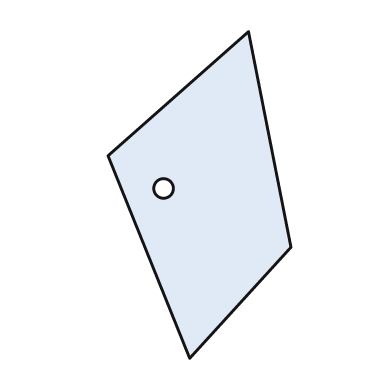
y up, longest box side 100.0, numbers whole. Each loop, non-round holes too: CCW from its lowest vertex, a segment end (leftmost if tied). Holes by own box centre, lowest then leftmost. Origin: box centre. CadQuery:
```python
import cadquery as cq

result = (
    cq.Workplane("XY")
    .moveTo(-3.0, -50.0)
    .lineTo(28.0, -16.0)
    .lineTo(15.0, 50.0)
    .lineTo(-28.0, 12.0)
    .close()
    .moveTo(-11.0, 2.0)
    .circle(3.0)
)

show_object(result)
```